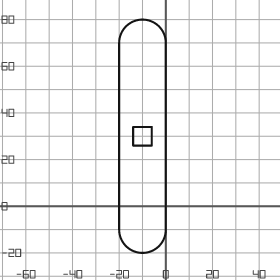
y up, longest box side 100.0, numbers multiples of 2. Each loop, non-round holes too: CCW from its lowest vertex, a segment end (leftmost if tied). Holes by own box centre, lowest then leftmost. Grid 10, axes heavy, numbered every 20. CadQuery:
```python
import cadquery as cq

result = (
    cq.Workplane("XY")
    .moveTo(-20.0, -10.0)
    .threePointArc((-10.0, -20.0), (0.0, -10.0))
    .lineTo(0.0, 70.0)
    .threePointArc((-10.0, 80.0), (-20.0, 70.0))
    .close()
    .moveTo(-14.0, 26.0)
    .lineTo(-6.0, 26.0)
    .lineTo(-6.0, 34.0)
    .lineTo(-14.0, 34.0)
    .close()
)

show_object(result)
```